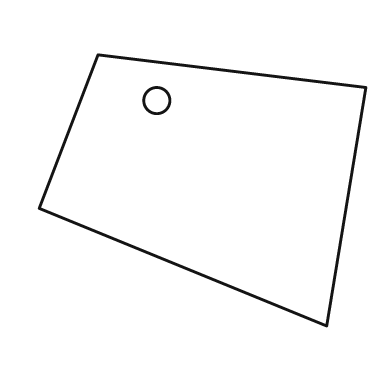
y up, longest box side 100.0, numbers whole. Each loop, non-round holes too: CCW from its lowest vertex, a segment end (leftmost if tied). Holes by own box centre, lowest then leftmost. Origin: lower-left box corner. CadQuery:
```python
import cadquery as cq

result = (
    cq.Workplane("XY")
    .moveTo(88.0, 0.0)
    .lineTo(100.0, 73.0)
    .lineTo(18.0, 83.0)
    .lineTo(0.0, 36.0)
    .close()
    .moveTo(36.0, 69.0)
    .circle(4.0)
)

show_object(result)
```